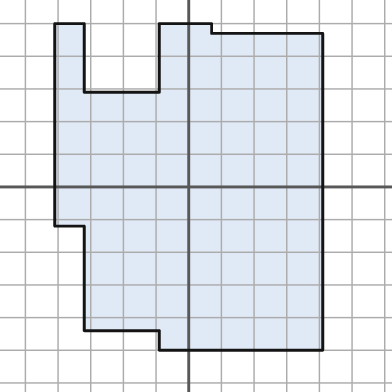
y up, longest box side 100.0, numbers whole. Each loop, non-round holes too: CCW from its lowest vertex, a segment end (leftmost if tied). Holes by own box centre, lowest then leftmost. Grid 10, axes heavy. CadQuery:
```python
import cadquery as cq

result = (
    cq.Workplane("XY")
    .moveTo(-9.0, -50.0)
    .lineTo(41.0, -50.0)
    .lineTo(41.0, 47.0)
    .lineTo(7.0, 47.0)
    .lineTo(7.0, 50.0)
    .lineTo(-9.0, 50.0)
    .lineTo(-9.0, 29.0)
    .lineTo(-32.0, 29.0)
    .lineTo(-32.0, 50.0)
    .lineTo(-41.0, 50.0)
    .lineTo(-41.0, -12.0)
    .lineTo(-32.0, -12.0)
    .lineTo(-32.0, -44.0)
    .lineTo(-9.0, -44.0)
    .close()
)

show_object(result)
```